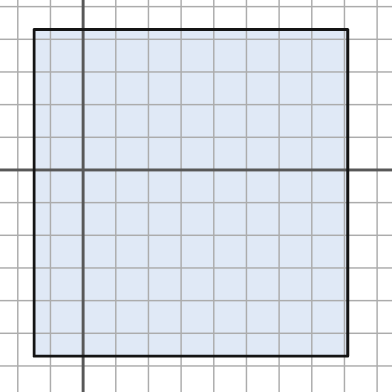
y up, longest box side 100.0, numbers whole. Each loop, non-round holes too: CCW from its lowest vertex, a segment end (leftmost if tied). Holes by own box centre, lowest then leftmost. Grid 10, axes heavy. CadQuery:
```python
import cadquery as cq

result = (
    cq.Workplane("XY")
    .moveTo(-15.0, -57.0)
    .lineTo(81.0, -57.0)
    .lineTo(81.0, 43.0)
    .lineTo(-15.0, 43.0)
    .close()
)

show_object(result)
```